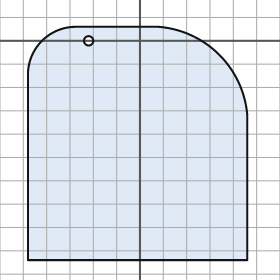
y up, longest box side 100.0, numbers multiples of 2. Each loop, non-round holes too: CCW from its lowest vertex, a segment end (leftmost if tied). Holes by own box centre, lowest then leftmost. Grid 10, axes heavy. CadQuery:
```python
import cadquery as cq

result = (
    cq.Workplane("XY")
    .moveTo(-48.0, -94.0)
    .lineTo(46.0, -94.0)
    .lineTo(46.0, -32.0)
    .threePointArc((34.0, -6.0), (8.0, 6.0))
    .lineTo(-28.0, 6.0)
    .threePointArc((-42.0, 0.0), (-48.0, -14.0))
    .close()
    .moveTo(-22.0, 0.0)
    .circle(2.0)
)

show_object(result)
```